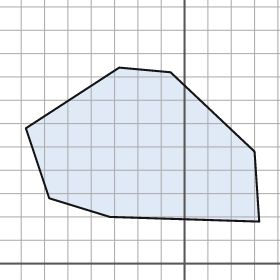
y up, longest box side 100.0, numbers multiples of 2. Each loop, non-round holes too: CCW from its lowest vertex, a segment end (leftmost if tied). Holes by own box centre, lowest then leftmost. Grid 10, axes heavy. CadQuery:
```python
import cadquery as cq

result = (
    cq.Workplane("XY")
    .moveTo(32.0, 18.0)
    .lineTo(30.0, 48.0)
    .lineTo(-6.0, 82.0)
    .lineTo(-28.0, 84.0)
    .lineTo(-68.0, 58.0)
    .lineTo(-58.0, 28.0)
    .lineTo(-32.0, 20.0)
    .close()
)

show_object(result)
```